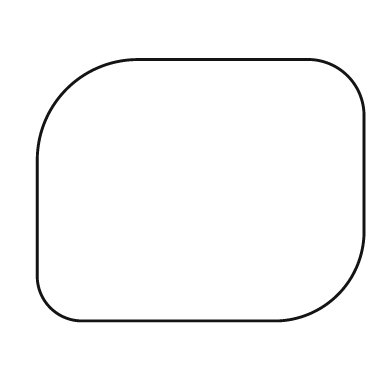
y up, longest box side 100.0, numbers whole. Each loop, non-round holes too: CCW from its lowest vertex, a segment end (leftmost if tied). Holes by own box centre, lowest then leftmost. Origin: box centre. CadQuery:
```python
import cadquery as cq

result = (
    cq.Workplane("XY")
    .moveTo(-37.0, -40.0)
    .lineTo(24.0, -40.0)
    .threePointArc((42.0, -32.0), (50.0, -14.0))
    .lineTo(50.0, 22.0)
    .threePointArc((45.0, 35.0), (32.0, 40.0))
    .lineTo(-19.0, 40.0)
    .threePointArc((-41.0, 31.0), (-50.0, 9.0))
    .lineTo(-50.0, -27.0)
    .threePointArc((-46.0, -36.0), (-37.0, -40.0))
    .close()
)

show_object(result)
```